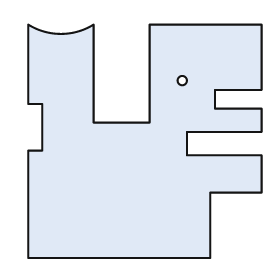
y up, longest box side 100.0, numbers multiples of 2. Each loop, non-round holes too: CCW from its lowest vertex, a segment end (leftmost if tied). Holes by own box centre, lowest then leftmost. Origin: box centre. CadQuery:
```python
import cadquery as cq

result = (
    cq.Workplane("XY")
    .moveTo(-50.0, -50.0)
    .lineTo(28.0, -50.0)
    .lineTo(28.0, -22.0)
    .lineTo(50.0, -22.0)
    .lineTo(50.0, -6.0)
    .lineTo(18.0, -6.0)
    .lineTo(18.0, 4.0)
    .lineTo(50.0, 4.0)
    .lineTo(50.0, 14.0)
    .lineTo(30.0, 14.0)
    .lineTo(30.0, 22.0)
    .lineTo(50.0, 22.0)
    .lineTo(50.0, 50.0)
    .lineTo(2.0, 50.0)
    .lineTo(2.0, 8.0)
    .lineTo(-22.0, 8.0)
    .lineTo(-22.0, 50.0)
    .threePointArc((-36.0, 46.0), (-50.0, 50.0))
    .lineTo(-50.0, 16.0)
    .lineTo(-44.0, 16.0)
    .lineTo(-44.0, -4.0)
    .lineTo(-50.0, -4.0)
    .close()
    .moveTo(16.0, 26.0)
    .circle(2.0)
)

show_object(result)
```